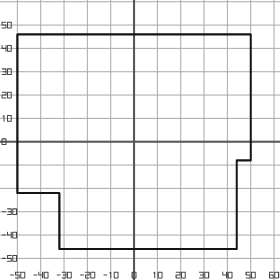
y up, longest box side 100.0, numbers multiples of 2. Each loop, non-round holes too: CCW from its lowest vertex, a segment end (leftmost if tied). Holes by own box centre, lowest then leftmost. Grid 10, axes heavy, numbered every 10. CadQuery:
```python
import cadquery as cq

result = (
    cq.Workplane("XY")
    .moveTo(-32.0, -46.0)
    .lineTo(44.0, -46.0)
    .lineTo(44.0, -8.0)
    .lineTo(50.0, -8.0)
    .lineTo(50.0, 46.0)
    .lineTo(-50.0, 46.0)
    .lineTo(-50.0, -22.0)
    .lineTo(-32.0, -22.0)
    .close()
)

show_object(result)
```